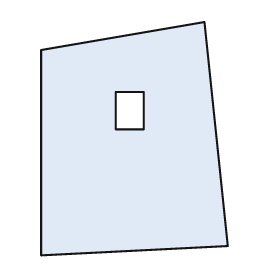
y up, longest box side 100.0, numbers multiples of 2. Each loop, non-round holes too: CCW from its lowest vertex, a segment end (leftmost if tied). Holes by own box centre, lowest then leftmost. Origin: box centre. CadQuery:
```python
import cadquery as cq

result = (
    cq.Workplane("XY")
    .moveTo(-40.0, -50.0)
    .lineTo(40.0, -46.0)
    .lineTo(30.0, 50.0)
    .lineTo(-40.0, 38.0)
    .close()
    .moveTo(-8.0, 4.0)
    .lineTo(4.0, 4.0)
    .lineTo(4.0, 20.0)
    .lineTo(-8.0, 20.0)
    .close()
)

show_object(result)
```